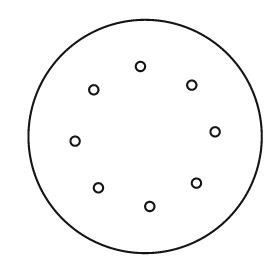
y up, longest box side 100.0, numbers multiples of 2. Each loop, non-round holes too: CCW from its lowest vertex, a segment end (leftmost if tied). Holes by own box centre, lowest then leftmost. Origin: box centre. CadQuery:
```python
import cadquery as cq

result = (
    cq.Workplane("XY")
    .moveTo(0.0, 0.0)
    .circle(50.0)
    .moveTo(2.0, -30.0)
    .circle(2.0)
    .moveTo(-20.0, -22.0)
    .circle(2.0)
    .moveTo(22.0, -20.0)
    .circle(2.0)
    .moveTo(-30.0, -2.0)
    .circle(2.0)
    .moveTo(30.0, 2.0)
    .circle(2.0)
    .moveTo(-22.0, 20.0)
    .circle(2.0)
    .moveTo(20.0, 22.0)
    .circle(2.0)
    .moveTo(-2.0, 30.0)
    .circle(2.0)
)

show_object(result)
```